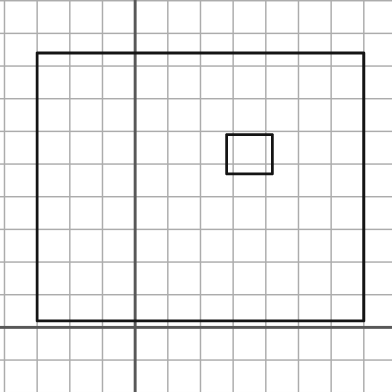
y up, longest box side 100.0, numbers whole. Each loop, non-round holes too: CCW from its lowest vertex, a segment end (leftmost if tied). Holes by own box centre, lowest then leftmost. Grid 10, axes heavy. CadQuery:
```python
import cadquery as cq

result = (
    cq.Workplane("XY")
    .moveTo(-30.0, 2.0)
    .lineTo(70.0, 2.0)
    .lineTo(70.0, 84.0)
    .lineTo(-30.0, 84.0)
    .close()
    .moveTo(28.0, 47.0)
    .lineTo(42.0, 47.0)
    .lineTo(42.0, 59.0)
    .lineTo(28.0, 59.0)
    .close()
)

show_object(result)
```